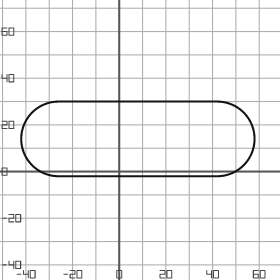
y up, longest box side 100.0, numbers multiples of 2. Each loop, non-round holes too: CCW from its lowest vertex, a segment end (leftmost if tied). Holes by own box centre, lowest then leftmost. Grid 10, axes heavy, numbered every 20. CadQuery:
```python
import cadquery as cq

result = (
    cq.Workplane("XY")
    .moveTo(-26.0, -2.0)
    .lineTo(42.0, -2.0)
    .threePointArc((58.0, 14.0), (42.0, 30.0))
    .lineTo(-26.0, 30.0)
    .threePointArc((-42.0, 14.0), (-26.0, -2.0))
    .close()
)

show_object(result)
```